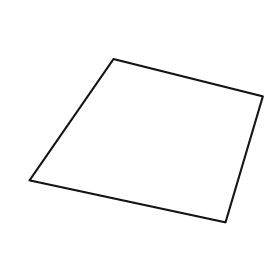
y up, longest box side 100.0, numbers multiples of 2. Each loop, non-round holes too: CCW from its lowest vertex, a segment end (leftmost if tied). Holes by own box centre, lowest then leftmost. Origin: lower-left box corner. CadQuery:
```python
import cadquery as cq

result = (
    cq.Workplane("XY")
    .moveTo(84.0, 0.0)
    .lineTo(100.0, 54.0)
    .lineTo(36.0, 70.0)
    .lineTo(0.0, 18.0)
    .close()
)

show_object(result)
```